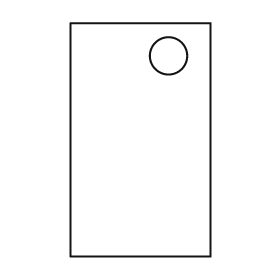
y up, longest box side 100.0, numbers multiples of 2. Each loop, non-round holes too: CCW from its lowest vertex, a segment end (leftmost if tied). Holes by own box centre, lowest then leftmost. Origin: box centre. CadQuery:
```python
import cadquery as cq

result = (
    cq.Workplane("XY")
    .moveTo(-30.0, -50.0)
    .lineTo(30.0, -50.0)
    .lineTo(30.0, 50.0)
    .lineTo(-30.0, 50.0)
    .close()
    .moveTo(12.0, 36.0)
    .circle(8.0)
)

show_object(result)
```